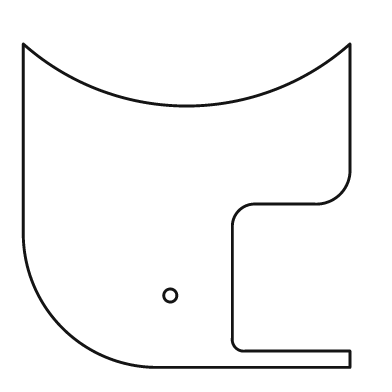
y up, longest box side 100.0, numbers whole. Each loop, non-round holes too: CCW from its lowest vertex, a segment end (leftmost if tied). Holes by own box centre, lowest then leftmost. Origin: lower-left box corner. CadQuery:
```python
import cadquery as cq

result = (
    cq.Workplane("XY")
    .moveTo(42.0, 0.0)
    .lineTo(100.0, 0.0)
    .lineTo(100.0, 5.0)
    .lineTo(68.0, 5.0)
    .threePointArc((65.0, 6.0), (64.0, 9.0))
    .lineTo(64.0, 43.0)
    .threePointArc((66.0, 48.0), (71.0, 50.0))
    .lineTo(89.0, 50.0)
    .threePointArc((97.0, 53.0), (100.0, 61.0))
    .lineTo(100.0, 99.0)
    .threePointArc((50.0, 80.0), (0.0, 99.0))
    .lineTo(0.0, 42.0)
    .threePointArc((12.0, 12.0), (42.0, 0.0))
    .close()
    .moveTo(45.0, 22.0)
    .circle(2.0)
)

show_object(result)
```